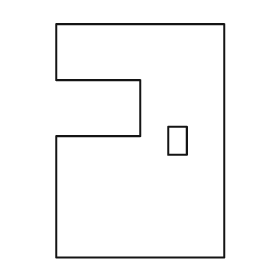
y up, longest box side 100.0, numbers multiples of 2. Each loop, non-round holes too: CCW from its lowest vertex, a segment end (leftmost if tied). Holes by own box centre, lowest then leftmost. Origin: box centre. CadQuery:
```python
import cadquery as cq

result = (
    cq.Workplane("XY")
    .moveTo(-36.0, -50.0)
    .lineTo(36.0, -50.0)
    .lineTo(36.0, 50.0)
    .lineTo(-36.0, 50.0)
    .lineTo(-36.0, 26.0)
    .lineTo(0.0, 26.0)
    .lineTo(0.0, 2.0)
    .lineTo(-36.0, 2.0)
    .close()
    .moveTo(12.0, -6.0)
    .lineTo(20.0, -6.0)
    .lineTo(20.0, 6.0)
    .lineTo(12.0, 6.0)
    .close()
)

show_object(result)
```